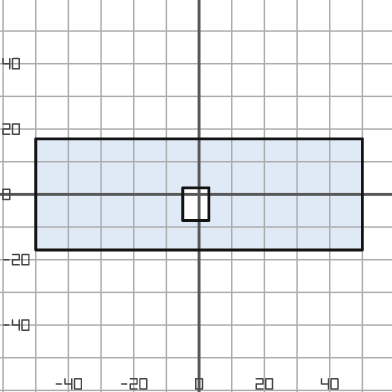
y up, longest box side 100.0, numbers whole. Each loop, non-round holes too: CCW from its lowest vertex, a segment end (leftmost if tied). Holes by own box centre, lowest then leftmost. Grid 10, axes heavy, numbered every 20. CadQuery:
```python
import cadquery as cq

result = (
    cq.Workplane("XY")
    .moveTo(-50.0, -17.0)
    .lineTo(50.0, -17.0)
    .lineTo(50.0, 17.0)
    .lineTo(-50.0, 17.0)
    .close()
    .moveTo(-5.0, -8.0)
    .lineTo(3.0, -8.0)
    .lineTo(3.0, 2.0)
    .lineTo(-5.0, 2.0)
    .close()
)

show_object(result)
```